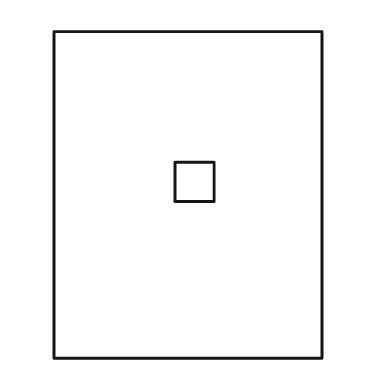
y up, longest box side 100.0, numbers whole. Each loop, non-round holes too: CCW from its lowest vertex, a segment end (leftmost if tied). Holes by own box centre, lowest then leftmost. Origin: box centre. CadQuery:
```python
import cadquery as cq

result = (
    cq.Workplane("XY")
    .moveTo(-41.0, -50.0)
    .lineTo(41.0, -50.0)
    .lineTo(41.0, 50.0)
    .lineTo(-41.0, 50.0)
    .close()
    .moveTo(-4.0, -2.0)
    .lineTo(8.0, -2.0)
    .lineTo(8.0, 10.0)
    .lineTo(-4.0, 10.0)
    .close()
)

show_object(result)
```